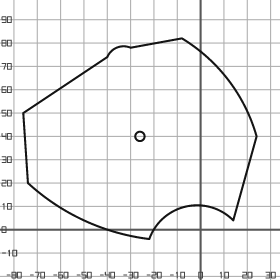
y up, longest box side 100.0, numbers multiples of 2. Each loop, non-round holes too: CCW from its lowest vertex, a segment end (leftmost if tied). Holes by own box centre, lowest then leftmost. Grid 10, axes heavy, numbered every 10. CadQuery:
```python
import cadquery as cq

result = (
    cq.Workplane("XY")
    .moveTo(-22.0, -4.0)
    .threePointArc((-6.0, 10.0), (14.0, 4.0))
    .lineTo(24.0, 40.0)
    .threePointArc((12.0, 64.0), (-8.0, 82.0))
    .lineTo(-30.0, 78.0)
    .threePointArc((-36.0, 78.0), (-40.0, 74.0))
    .lineTo(-76.0, 50.0)
    .lineTo(-74.0, 20.0)
    .threePointArc((-50.0, 4.0), (-22.0, -4.0))
    .close()
    .moveTo(-26.0, 40.0)
    .circle(2.0)
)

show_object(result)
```